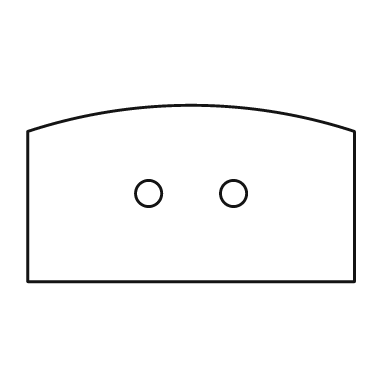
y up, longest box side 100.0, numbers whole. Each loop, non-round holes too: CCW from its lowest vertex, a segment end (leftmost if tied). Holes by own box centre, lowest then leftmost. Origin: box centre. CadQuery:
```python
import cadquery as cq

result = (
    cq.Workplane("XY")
    .moveTo(-50.0, -27.0)
    .lineTo(50.0, -27.0)
    .lineTo(50.0, 19.0)
    .threePointArc((0.0, 27.0), (-50.0, 19.0))
    .close()
    .moveTo(-13.0, 0.0)
    .circle(4.0)
    .moveTo(13.0, 0.0)
    .circle(4.0)
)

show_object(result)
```